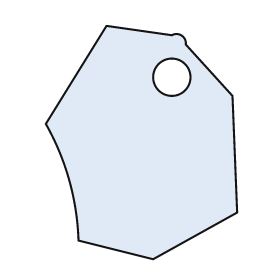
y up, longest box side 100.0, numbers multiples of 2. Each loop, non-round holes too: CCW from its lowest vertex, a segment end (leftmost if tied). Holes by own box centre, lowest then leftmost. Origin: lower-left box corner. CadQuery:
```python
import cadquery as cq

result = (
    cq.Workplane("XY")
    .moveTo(46.0, 0.0)
    .lineTo(82.0, 20.0)
    .lineTo(80.0, 70.0)
    .lineTo(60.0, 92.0)
    .threePointArc((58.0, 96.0), (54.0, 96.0))
    .lineTo(26.0, 100.0)
    .lineTo(0.0, 58.0)
    .threePointArc((10.0, 34.0), (14.0, 8.0))
    .close()
    .moveTo(54.0, 78.0)
    .circle(8.0)
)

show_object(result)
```